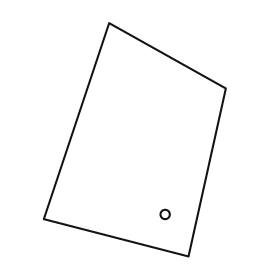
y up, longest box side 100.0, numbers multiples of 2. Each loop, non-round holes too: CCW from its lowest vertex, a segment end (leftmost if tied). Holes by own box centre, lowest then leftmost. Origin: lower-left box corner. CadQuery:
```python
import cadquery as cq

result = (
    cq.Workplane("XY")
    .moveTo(62.0, 0.0)
    .lineTo(78.0, 72.0)
    .lineTo(28.0, 100.0)
    .lineTo(0.0, 16.0)
    .close()
    .moveTo(52.0, 18.0)
    .circle(2.0)
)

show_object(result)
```